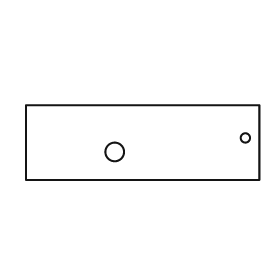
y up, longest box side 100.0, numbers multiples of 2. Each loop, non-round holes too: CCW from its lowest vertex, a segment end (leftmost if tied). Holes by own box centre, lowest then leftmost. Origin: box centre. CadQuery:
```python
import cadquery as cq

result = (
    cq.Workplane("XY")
    .moveTo(-50.0, -16.0)
    .lineTo(50.0, -16.0)
    .lineTo(50.0, 16.0)
    .lineTo(-50.0, 16.0)
    .close()
    .moveTo(-12.0, -4.0)
    .circle(4.0)
    .moveTo(44.0, 2.0)
    .circle(2.0)
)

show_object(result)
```